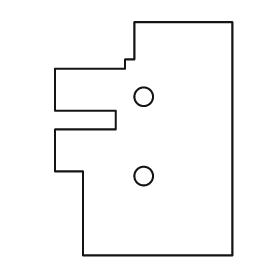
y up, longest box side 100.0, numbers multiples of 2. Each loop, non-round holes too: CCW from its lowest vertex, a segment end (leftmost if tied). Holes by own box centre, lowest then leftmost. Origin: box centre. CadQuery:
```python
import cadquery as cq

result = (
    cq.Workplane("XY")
    .moveTo(-26.0, -50.0)
    .lineTo(38.0, -50.0)
    .lineTo(38.0, 50.0)
    .lineTo(-4.0, 50.0)
    .lineTo(-4.0, 34.0)
    .lineTo(-8.0, 34.0)
    .lineTo(-8.0, 30.0)
    .lineTo(-38.0, 30.0)
    .lineTo(-38.0, 12.0)
    .lineTo(-12.0, 12.0)
    .lineTo(-12.0, 4.0)
    .lineTo(-38.0, 4.0)
    .lineTo(-38.0, -14.0)
    .lineTo(-26.0, -14.0)
    .close()
    .moveTo(0.0, -16.0)
    .circle(4.0)
    .moveTo(0.0, 18.0)
    .circle(4.0)
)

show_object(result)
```